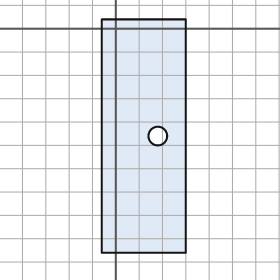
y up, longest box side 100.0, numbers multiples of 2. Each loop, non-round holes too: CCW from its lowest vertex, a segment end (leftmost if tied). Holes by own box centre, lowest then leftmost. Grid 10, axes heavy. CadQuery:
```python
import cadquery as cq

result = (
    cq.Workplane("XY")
    .moveTo(-6.0, -96.0)
    .lineTo(30.0, -96.0)
    .lineTo(30.0, 4.0)
    .lineTo(-6.0, 4.0)
    .close()
    .moveTo(18.0, -46.0)
    .circle(4.0)
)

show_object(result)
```